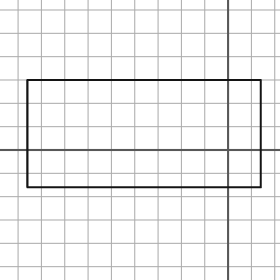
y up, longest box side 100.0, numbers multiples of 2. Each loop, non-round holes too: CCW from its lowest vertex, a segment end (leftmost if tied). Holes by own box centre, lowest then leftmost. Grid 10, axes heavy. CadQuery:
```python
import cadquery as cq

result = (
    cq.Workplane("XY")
    .moveTo(-86.0, -16.0)
    .lineTo(14.0, -16.0)
    .lineTo(14.0, 30.0)
    .lineTo(-86.0, 30.0)
    .close()
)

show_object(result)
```